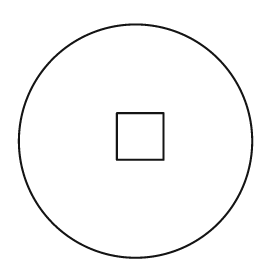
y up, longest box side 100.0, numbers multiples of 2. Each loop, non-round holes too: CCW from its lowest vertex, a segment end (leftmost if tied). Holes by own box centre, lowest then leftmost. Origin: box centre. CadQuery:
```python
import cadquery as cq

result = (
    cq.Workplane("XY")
    .moveTo(0.0, 0.0)
    .circle(50.0)
    .moveTo(-8.0, -8.0)
    .lineTo(12.0, -8.0)
    .lineTo(12.0, 12.0)
    .lineTo(-8.0, 12.0)
    .close()
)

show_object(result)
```